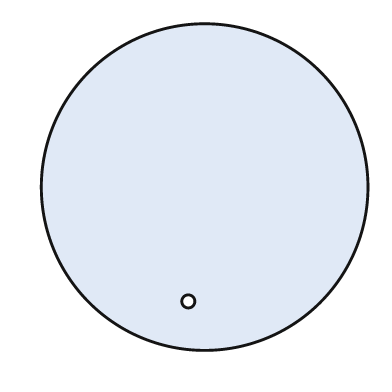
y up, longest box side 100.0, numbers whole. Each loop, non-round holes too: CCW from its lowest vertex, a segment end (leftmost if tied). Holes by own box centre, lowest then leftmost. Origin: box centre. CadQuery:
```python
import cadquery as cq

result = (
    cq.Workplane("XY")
    .moveTo(0.0, 0.0)
    .circle(50.0)
    .moveTo(-5.0, -35.0)
    .circle(2.0)
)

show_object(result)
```